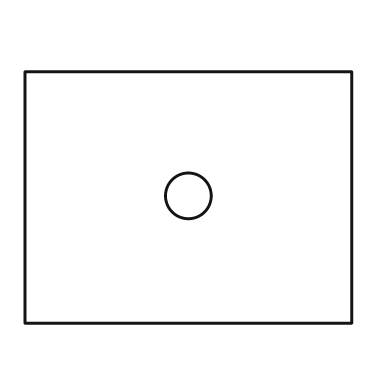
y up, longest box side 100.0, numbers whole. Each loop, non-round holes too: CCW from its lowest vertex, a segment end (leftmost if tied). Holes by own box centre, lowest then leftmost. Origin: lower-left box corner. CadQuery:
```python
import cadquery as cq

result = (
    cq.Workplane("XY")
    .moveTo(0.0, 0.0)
    .lineTo(100.0, 0.0)
    .lineTo(100.0, 77.0)
    .lineTo(0.0, 77.0)
    .close()
    .moveTo(50.0, 39.0)
    .circle(7.0)
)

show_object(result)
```